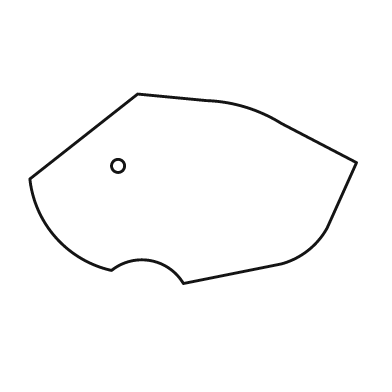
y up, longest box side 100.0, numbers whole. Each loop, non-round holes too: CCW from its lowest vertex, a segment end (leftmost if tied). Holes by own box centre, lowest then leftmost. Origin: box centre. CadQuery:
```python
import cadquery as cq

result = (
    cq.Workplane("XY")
    .moveTo(-3.0, -29.0)
    .lineTo(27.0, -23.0)
    .threePointArc((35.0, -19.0), (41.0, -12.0))
    .lineTo(50.0, 8.0)
    .lineTo(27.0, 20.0)
    .threePointArc((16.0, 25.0), (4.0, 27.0))
    .lineTo(-17.0, 29.0)
    .lineTo(-50.0, 3.0)
    .threePointArc((-42.0, -15.0), (-25.0, -25.0))
    .threePointArc((-13.0, -22.0), (-3.0, -29.0))
    .close()
    .moveTo(-23.0, 7.0)
    .circle(2.0)
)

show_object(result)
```